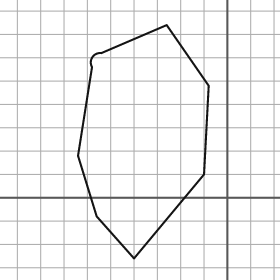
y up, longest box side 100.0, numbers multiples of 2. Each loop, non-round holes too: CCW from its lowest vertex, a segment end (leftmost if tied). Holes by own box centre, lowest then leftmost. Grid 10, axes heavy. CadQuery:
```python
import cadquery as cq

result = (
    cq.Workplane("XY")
    .moveTo(-40.0, -26.0)
    .lineTo(-10.0, 10.0)
    .lineTo(-8.0, 48.0)
    .lineTo(-26.0, 74.0)
    .lineTo(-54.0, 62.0)
    .threePointArc((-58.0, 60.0), (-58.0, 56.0))
    .lineTo(-64.0, 18.0)
    .lineTo(-56.0, -8.0)
    .close()
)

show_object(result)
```